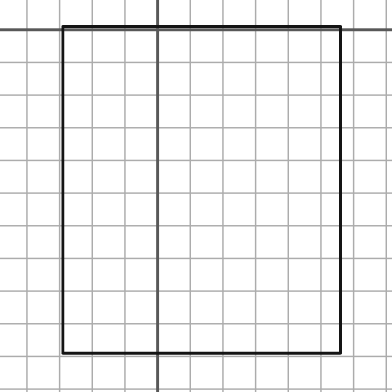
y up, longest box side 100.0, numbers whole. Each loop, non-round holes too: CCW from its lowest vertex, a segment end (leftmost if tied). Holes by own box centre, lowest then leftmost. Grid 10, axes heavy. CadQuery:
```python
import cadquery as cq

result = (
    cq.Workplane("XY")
    .moveTo(-29.0, -99.0)
    .lineTo(56.0, -99.0)
    .lineTo(56.0, 1.0)
    .lineTo(-29.0, 1.0)
    .close()
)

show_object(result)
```